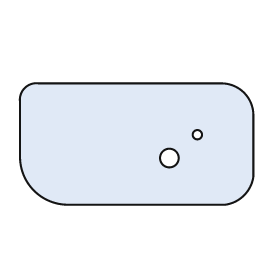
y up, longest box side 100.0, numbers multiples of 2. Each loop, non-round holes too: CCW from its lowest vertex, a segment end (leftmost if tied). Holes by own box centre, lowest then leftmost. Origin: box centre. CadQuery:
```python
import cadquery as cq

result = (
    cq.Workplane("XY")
    .moveTo(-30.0, -26.0)
    .lineTo(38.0, -26.0)
    .threePointArc((46.0, -22.0), (50.0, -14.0))
    .lineTo(50.0, 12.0)
    .threePointArc((46.0, 22.0), (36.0, 26.0))
    .lineTo(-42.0, 26.0)
    .threePointArc((-48.0, 24.0), (-50.0, 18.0))
    .lineTo(-50.0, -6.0)
    .threePointArc((-44.0, -20.0), (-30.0, -26.0))
    .close()
    .moveTo(14.0, -6.0)
    .circle(4.0)
    .moveTo(26.0, 4.0)
    .circle(2.0)
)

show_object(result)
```